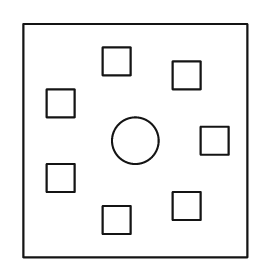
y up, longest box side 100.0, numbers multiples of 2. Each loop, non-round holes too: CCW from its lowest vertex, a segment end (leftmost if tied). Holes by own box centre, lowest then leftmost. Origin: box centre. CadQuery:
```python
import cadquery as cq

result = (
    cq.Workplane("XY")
    .moveTo(-48.0, -50.0)
    .lineTo(48.0, -50.0)
    .lineTo(48.0, 50.0)
    .lineTo(-48.0, 50.0)
    .close()
    .moveTo(-14.0, -40.0)
    .lineTo(-2.0, -40.0)
    .lineTo(-2.0, -28.0)
    .lineTo(-14.0, -28.0)
    .close()
    .moveTo(16.0, -34.0)
    .lineTo(28.0, -34.0)
    .lineTo(28.0, -22.0)
    .lineTo(16.0, -22.0)
    .close()
    .moveTo(-38.0, -22.0)
    .lineTo(-26.0, -22.0)
    .lineTo(-26.0, -10.0)
    .lineTo(-38.0, -10.0)
    .close()
    .moveTo(0.0, 0.0)
    .circle(10.0)
    .moveTo(28.0, -6.0)
    .lineTo(40.0, -6.0)
    .lineTo(40.0, 6.0)
    .lineTo(28.0, 6.0)
    .close()
    .moveTo(-38.0, 10.0)
    .lineTo(-26.0, 10.0)
    .lineTo(-26.0, 22.0)
    .lineTo(-38.0, 22.0)
    .close()
    .moveTo(16.0, 22.0)
    .lineTo(28.0, 22.0)
    .lineTo(28.0, 34.0)
    .lineTo(16.0, 34.0)
    .close()
    .moveTo(-14.0, 28.0)
    .lineTo(-2.0, 28.0)
    .lineTo(-2.0, 40.0)
    .lineTo(-14.0, 40.0)
    .close()
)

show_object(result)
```